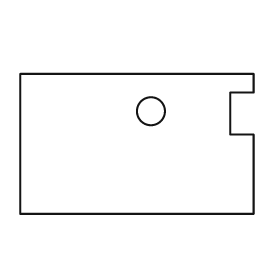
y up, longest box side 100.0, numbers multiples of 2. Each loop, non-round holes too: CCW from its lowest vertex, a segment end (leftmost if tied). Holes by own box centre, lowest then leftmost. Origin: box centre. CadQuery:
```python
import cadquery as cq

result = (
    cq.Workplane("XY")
    .moveTo(-50.0, -30.0)
    .lineTo(50.0, -30.0)
    .lineTo(50.0, 4.0)
    .lineTo(40.0, 4.0)
    .lineTo(40.0, 22.0)
    .lineTo(50.0, 22.0)
    .lineTo(50.0, 30.0)
    .lineTo(-50.0, 30.0)
    .close()
    .moveTo(6.0, 14.0)
    .circle(6.0)
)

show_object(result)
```